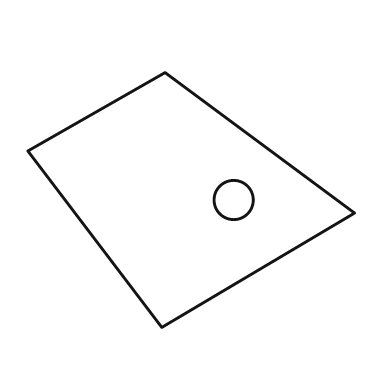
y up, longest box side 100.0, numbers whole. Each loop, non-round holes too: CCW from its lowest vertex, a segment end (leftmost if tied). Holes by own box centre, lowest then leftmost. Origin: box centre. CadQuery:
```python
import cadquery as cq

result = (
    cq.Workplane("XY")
    .moveTo(-9.0, -39.0)
    .lineTo(50.0, -4.0)
    .lineTo(-8.0, 39.0)
    .lineTo(-50.0, 15.0)
    .close()
    .moveTo(13.0, 0.0)
    .circle(6.0)
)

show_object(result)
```